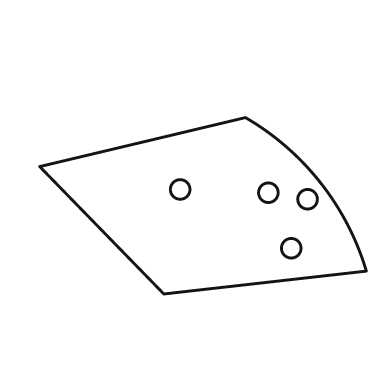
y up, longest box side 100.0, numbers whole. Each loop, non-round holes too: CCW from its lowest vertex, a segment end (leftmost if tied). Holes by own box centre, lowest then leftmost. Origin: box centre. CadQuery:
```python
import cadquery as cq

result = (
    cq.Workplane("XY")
    .moveTo(-12.0, -27.0)
    .lineTo(50.0, -20.0)
    .threePointArc((36.0, 7.0), (13.0, 27.0))
    .lineTo(-50.0, 12.0)
    .close()
    .moveTo(27.0, -13.0)
    .circle(3.0)
    .moveTo(32.0, 2.0)
    .circle(3.0)
    .moveTo(20.0, 4.0)
    .circle(3.0)
    .moveTo(-7.0, 5.0)
    .circle(3.0)
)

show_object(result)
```